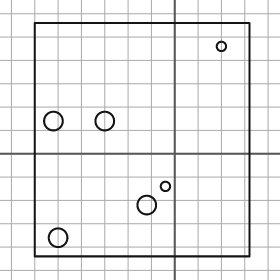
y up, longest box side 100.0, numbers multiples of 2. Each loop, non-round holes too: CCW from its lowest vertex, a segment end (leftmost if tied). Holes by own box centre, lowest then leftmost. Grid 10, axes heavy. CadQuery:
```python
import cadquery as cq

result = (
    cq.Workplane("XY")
    .moveTo(-60.0, -44.0)
    .lineTo(32.0, -44.0)
    .lineTo(32.0, 56.0)
    .lineTo(-60.0, 56.0)
    .close()
    .moveTo(-50.0, -36.0)
    .circle(4.0)
    .moveTo(-12.0, -22.0)
    .circle(4.0)
    .moveTo(-4.0, -14.0)
    .circle(2.0)
    .moveTo(-52.0, 14.0)
    .circle(4.0)
    .moveTo(-30.0, 14.0)
    .circle(4.0)
    .moveTo(20.0, 46.0)
    .circle(2.0)
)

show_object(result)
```